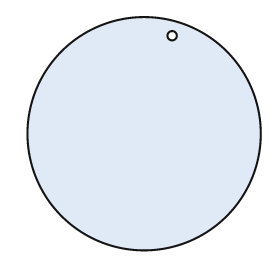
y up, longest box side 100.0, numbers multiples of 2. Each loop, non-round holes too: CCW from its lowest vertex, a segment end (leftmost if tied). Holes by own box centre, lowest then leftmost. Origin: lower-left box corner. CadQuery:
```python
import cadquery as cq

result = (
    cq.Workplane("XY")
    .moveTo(50.0, 50.0)
    .circle(50.0)
    .moveTo(62.0, 92.0)
    .circle(2.0)
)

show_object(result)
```